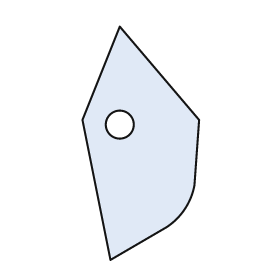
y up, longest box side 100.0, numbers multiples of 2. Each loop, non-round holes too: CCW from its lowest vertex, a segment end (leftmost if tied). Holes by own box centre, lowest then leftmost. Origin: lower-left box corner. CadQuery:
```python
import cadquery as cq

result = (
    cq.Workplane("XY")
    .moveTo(12.0, 0.0)
    .lineTo(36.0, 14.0)
    .threePointArc((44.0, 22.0), (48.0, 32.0))
    .lineTo(50.0, 60.0)
    .lineTo(16.0, 100.0)
    .lineTo(0.0, 60.0)
    .close()
    .moveTo(16.0, 58.0)
    .circle(6.0)
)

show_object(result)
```